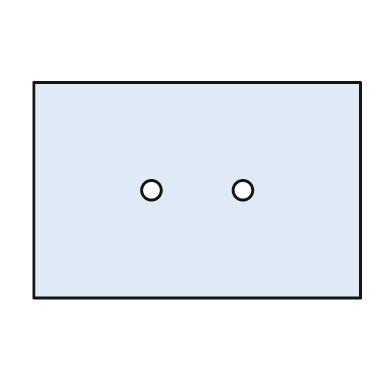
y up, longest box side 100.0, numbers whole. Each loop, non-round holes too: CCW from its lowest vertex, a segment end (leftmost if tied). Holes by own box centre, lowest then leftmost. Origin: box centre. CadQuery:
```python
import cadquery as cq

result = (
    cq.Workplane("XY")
    .moveTo(-50.0, -33.0)
    .lineTo(50.0, -33.0)
    .lineTo(50.0, 33.0)
    .lineTo(-50.0, 33.0)
    .close()
    .moveTo(-14.0, 0.0)
    .circle(3.0)
    .moveTo(14.0, 0.0)
    .circle(3.0)
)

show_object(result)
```